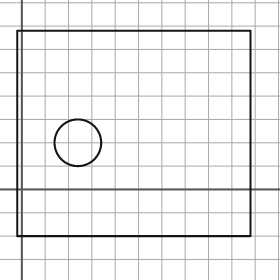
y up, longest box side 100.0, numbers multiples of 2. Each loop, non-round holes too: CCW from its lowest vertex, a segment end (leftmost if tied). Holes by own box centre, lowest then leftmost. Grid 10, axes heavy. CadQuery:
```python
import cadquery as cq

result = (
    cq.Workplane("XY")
    .moveTo(-2.0, -20.0)
    .lineTo(98.0, -20.0)
    .lineTo(98.0, 68.0)
    .lineTo(-2.0, 68.0)
    .close()
    .moveTo(24.0, 20.0)
    .circle(10.0)
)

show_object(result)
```